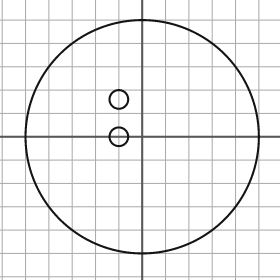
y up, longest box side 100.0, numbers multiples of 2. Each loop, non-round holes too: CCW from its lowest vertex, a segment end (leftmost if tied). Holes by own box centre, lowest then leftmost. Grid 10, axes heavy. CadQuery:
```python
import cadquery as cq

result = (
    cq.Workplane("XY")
    .moveTo(0.0, 0.0)
    .circle(50.0)
    .moveTo(-10.0, 0.0)
    .circle(4.0)
    .moveTo(-10.0, 16.0)
    .circle(4.0)
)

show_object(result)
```